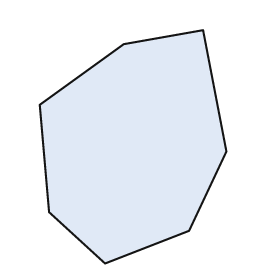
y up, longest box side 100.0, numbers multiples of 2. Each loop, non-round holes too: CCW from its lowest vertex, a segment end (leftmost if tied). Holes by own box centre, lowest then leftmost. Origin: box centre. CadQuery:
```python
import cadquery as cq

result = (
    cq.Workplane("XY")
    .moveTo(-12.0, -50.0)
    .lineTo(24.0, -36.0)
    .lineTo(40.0, -2.0)
    .lineTo(30.0, 50.0)
    .lineTo(-4.0, 44.0)
    .lineTo(-40.0, 18.0)
    .lineTo(-36.0, -28.0)
    .close()
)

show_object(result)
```